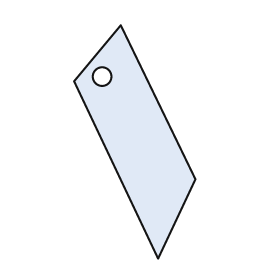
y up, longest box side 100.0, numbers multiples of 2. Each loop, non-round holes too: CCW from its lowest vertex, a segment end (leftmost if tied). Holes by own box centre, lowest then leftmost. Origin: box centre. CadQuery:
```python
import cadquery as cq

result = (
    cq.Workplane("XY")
    .moveTo(10.0, -50.0)
    .lineTo(26.0, -16.0)
    .lineTo(-6.0, 50.0)
    .lineTo(-26.0, 26.0)
    .close()
    .moveTo(-14.0, 28.0)
    .circle(4.0)
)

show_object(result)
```